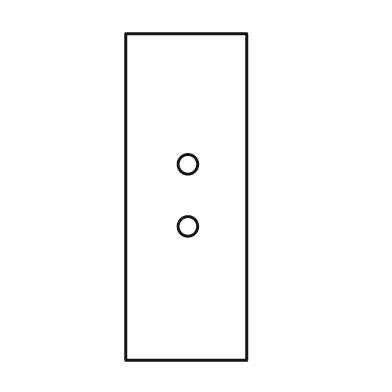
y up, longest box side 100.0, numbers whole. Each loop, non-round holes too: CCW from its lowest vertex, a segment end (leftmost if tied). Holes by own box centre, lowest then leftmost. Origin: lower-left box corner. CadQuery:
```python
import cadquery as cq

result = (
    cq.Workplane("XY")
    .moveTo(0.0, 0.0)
    .lineTo(37.0, 0.0)
    .lineTo(37.0, 100.0)
    .lineTo(0.0, 100.0)
    .close()
    .moveTo(19.0, 41.0)
    .circle(3.0)
    .moveTo(19.0, 60.0)
    .circle(3.0)
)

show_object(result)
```